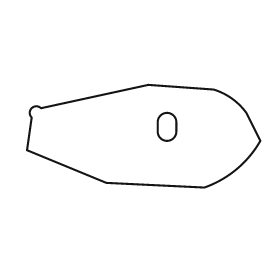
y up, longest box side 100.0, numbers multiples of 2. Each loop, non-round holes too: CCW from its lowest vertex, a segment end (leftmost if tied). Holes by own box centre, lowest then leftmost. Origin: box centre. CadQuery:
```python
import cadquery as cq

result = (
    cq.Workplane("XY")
    .moveTo(26.0, -22.0)
    .threePointArc((40.0, -14.0), (50.0, -2.0))
    .lineTo(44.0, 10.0)
    .threePointArc((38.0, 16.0), (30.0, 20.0))
    .lineTo(2.0, 22.0)
    .lineTo(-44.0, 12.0)
    .threePointArc((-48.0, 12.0), (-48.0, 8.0))
    .lineTo(-50.0, -6.0)
    .lineTo(-16.0, -20.0)
    .close()
    .moveTo(6.0, 2.0)
    .threePointArc((10.0, -2.0), (14.0, 2.0))
    .lineTo(14.0, 6.0)
    .threePointArc((10.0, 10.0), (6.0, 6.0))
    .close()
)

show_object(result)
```